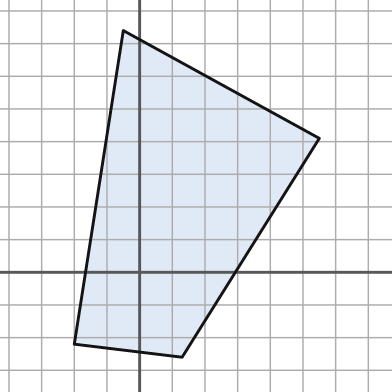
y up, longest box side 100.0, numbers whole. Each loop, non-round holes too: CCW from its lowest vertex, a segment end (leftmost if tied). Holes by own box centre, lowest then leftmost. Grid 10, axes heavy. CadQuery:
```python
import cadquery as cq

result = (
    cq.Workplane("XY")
    .moveTo(13.0, -26.0)
    .lineTo(55.0, 41.0)
    .lineTo(-5.0, 74.0)
    .lineTo(-20.0, -22.0)
    .close()
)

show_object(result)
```